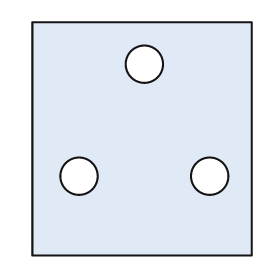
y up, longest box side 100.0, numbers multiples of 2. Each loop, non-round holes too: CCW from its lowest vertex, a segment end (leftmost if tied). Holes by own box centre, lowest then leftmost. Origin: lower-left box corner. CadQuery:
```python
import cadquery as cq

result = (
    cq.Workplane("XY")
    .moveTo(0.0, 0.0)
    .lineTo(94.0, 0.0)
    .lineTo(94.0, 100.0)
    .lineTo(0.0, 100.0)
    .close()
    .moveTo(20.0, 34.0)
    .circle(8.0)
    .moveTo(76.0, 34.0)
    .circle(8.0)
    .moveTo(48.0, 82.0)
    .circle(8.0)
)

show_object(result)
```